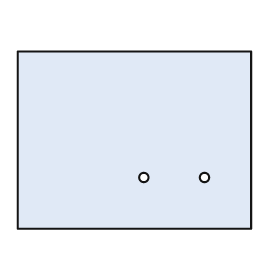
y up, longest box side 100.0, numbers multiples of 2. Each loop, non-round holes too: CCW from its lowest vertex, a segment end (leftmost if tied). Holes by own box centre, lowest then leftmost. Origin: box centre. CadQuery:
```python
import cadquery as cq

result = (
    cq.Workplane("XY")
    .moveTo(-50.0, -38.0)
    .lineTo(50.0, -38.0)
    .lineTo(50.0, 38.0)
    .lineTo(-50.0, 38.0)
    .close()
    .moveTo(4.0, -16.0)
    .circle(2.0)
    .moveTo(30.0, -16.0)
    .circle(2.0)
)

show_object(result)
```